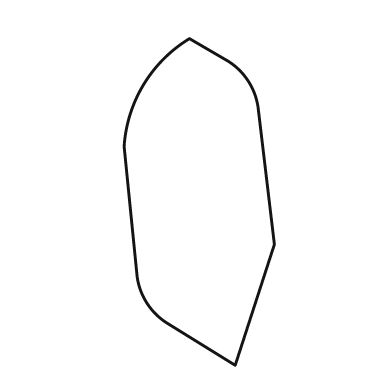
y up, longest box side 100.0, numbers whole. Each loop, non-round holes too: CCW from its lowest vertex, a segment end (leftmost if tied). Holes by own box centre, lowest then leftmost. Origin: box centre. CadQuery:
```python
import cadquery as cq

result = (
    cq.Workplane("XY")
    .moveTo(11.0, -50.0)
    .lineTo(23.0, -13.0)
    .lineTo(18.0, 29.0)
    .threePointArc((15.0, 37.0), (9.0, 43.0))
    .lineTo(-3.0, 50.0)
    .threePointArc((-17.0, 36.0), (-23.0, 17.0))
    .lineTo(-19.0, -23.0)
    .threePointArc((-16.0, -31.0), (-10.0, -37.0))
    .close()
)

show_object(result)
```